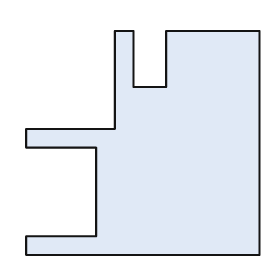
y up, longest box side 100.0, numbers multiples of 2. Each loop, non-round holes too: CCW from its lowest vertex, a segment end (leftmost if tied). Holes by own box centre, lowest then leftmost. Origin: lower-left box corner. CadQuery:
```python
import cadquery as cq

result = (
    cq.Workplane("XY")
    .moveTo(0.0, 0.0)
    .lineTo(100.0, 0.0)
    .lineTo(100.0, 96.0)
    .lineTo(60.0, 96.0)
    .lineTo(60.0, 72.0)
    .lineTo(46.0, 72.0)
    .lineTo(46.0, 96.0)
    .lineTo(38.0, 96.0)
    .lineTo(38.0, 54.0)
    .lineTo(0.0, 54.0)
    .lineTo(0.0, 46.0)
    .lineTo(30.0, 46.0)
    .lineTo(30.0, 8.0)
    .lineTo(0.0, 8.0)
    .close()
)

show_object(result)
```